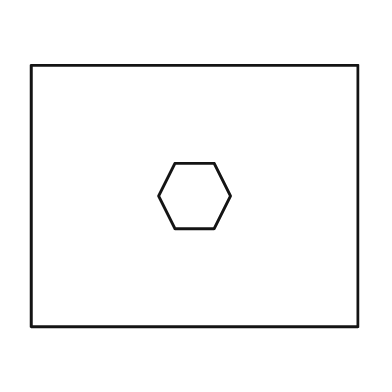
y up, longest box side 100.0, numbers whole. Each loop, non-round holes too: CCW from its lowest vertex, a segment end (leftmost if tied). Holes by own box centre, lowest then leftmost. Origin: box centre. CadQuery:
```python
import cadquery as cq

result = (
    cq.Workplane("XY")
    .moveTo(-50.0, -40.0)
    .lineTo(50.0, -40.0)
    .lineTo(50.0, 40.0)
    .lineTo(-50.0, 40.0)
    .close()
    .moveTo(-6.0, -10.0)
    .lineTo(6.0, -10.0)
    .lineTo(11.0, 0.0)
    .lineTo(6.0, 10.0)
    .lineTo(-6.0, 10.0)
    .lineTo(-11.0, 0.0)
    .close()
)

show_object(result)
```